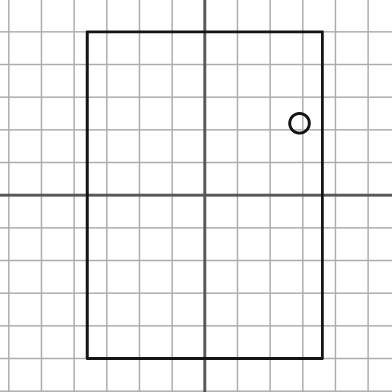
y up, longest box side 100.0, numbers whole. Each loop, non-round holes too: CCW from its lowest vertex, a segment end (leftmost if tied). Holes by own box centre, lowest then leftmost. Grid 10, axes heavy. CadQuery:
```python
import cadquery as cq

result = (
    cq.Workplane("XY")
    .moveTo(-36.0, -50.0)
    .lineTo(36.0, -50.0)
    .lineTo(36.0, 50.0)
    .lineTo(-36.0, 50.0)
    .close()
    .moveTo(29.0, 22.0)
    .circle(3.0)
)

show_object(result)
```